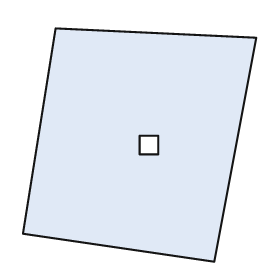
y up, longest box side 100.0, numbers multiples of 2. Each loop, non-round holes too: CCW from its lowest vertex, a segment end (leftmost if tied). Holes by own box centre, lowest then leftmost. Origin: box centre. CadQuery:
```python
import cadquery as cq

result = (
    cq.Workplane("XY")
    .moveTo(32.0, -50.0)
    .lineTo(50.0, 46.0)
    .lineTo(-36.0, 50.0)
    .lineTo(-50.0, -38.0)
    .close()
    .moveTo(0.0, -4.0)
    .lineTo(8.0, -4.0)
    .lineTo(8.0, 4.0)
    .lineTo(0.0, 4.0)
    .close()
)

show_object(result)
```